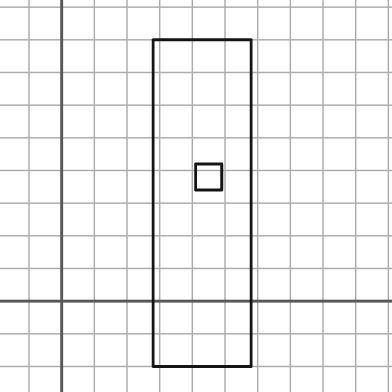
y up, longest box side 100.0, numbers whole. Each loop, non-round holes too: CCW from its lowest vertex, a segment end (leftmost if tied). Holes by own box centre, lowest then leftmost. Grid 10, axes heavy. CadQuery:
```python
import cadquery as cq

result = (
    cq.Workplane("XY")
    .moveTo(28.0, -20.0)
    .lineTo(58.0, -20.0)
    .lineTo(58.0, 80.0)
    .lineTo(28.0, 80.0)
    .close()
    .moveTo(41.0, 34.0)
    .lineTo(49.0, 34.0)
    .lineTo(49.0, 42.0)
    .lineTo(41.0, 42.0)
    .close()
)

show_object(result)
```